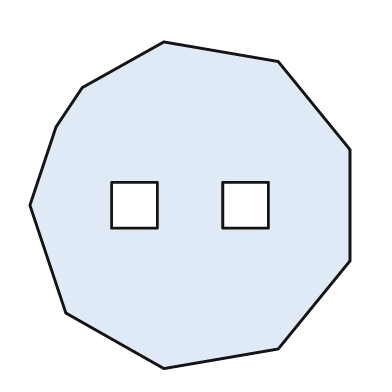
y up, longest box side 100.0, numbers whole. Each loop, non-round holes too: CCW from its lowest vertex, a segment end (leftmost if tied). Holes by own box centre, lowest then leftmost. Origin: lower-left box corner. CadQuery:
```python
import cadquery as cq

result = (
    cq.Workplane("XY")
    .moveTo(41.0, 0.0)
    .lineTo(76.0, 6.0)
    .lineTo(98.0, 33.0)
    .lineTo(98.0, 67.0)
    .lineTo(76.0, 94.0)
    .lineTo(41.0, 100.0)
    .lineTo(16.0, 86.0)
    .lineTo(8.0, 74.0)
    .lineTo(0.0, 50.0)
    .lineTo(11.0, 17.0)
    .close()
    .moveTo(25.0, 43.0)
    .lineTo(39.0, 43.0)
    .lineTo(39.0, 57.0)
    .lineTo(25.0, 57.0)
    .close()
    .moveTo(59.0, 43.0)
    .lineTo(73.0, 43.0)
    .lineTo(73.0, 57.0)
    .lineTo(59.0, 57.0)
    .close()
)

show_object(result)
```